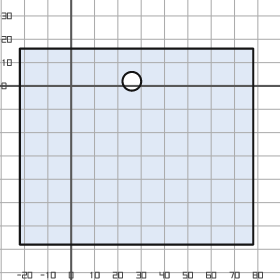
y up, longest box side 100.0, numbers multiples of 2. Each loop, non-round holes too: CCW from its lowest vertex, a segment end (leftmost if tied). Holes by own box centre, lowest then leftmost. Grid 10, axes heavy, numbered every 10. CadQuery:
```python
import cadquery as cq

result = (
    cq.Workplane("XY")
    .moveTo(-22.0, -68.0)
    .lineTo(78.0, -68.0)
    .lineTo(78.0, 16.0)
    .lineTo(-22.0, 16.0)
    .close()
    .moveTo(26.0, 2.0)
    .circle(4.0)
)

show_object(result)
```